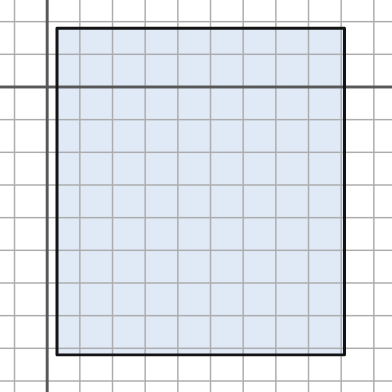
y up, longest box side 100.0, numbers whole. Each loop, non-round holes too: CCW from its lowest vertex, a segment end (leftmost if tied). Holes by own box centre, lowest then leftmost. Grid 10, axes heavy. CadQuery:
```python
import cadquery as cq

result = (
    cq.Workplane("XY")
    .moveTo(3.0, -82.0)
    .lineTo(91.0, -82.0)
    .lineTo(91.0, 18.0)
    .lineTo(3.0, 18.0)
    .close()
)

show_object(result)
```